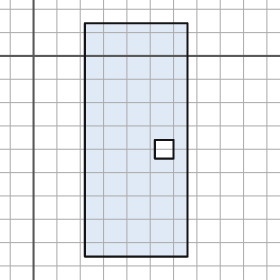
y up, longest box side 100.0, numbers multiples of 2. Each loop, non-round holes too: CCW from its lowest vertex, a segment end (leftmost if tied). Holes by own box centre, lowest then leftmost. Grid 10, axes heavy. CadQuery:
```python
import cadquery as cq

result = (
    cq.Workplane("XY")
    .moveTo(22.0, -86.0)
    .lineTo(66.0, -86.0)
    .lineTo(66.0, 14.0)
    .lineTo(22.0, 14.0)
    .close()
    .moveTo(52.0, -44.0)
    .lineTo(60.0, -44.0)
    .lineTo(60.0, -36.0)
    .lineTo(52.0, -36.0)
    .close()
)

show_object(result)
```